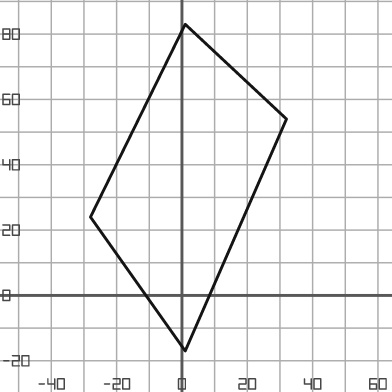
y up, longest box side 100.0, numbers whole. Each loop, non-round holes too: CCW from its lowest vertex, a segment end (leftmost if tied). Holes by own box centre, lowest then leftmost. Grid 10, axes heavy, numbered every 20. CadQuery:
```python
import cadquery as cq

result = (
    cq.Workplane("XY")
    .moveTo(1.0, -17.0)
    .lineTo(32.0, 54.0)
    .lineTo(1.0, 83.0)
    .lineTo(-28.0, 24.0)
    .close()
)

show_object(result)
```